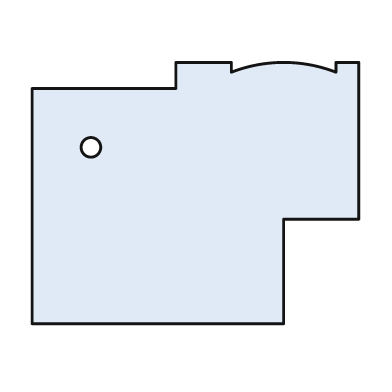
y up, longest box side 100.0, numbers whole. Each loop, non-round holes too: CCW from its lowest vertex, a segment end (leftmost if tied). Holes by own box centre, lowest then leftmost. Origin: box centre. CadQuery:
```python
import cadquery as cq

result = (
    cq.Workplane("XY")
    .moveTo(-50.0, -40.0)
    .lineTo(27.0, -40.0)
    .lineTo(27.0, -8.0)
    .lineTo(50.0, -8.0)
    .lineTo(50.0, 40.0)
    .lineTo(43.0, 40.0)
    .lineTo(43.0, 37.0)
    .threePointArc((27.0, 40.0), (11.0, 37.0))
    .lineTo(11.0, 40.0)
    .lineTo(-6.0, 40.0)
    .lineTo(-6.0, 32.0)
    .lineTo(-50.0, 32.0)
    .close()
    .moveTo(-32.0, 14.0)
    .circle(3.0)
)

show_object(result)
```